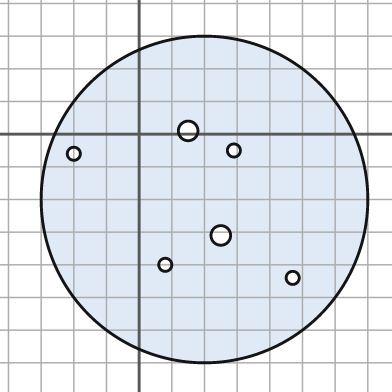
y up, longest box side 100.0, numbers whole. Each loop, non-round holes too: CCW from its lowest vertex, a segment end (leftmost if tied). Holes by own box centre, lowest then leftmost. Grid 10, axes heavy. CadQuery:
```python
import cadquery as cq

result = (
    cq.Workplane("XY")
    .moveTo(20.0, -20.0)
    .circle(50.0)
    .moveTo(47.0, -44.0)
    .circle(2.0)
    .moveTo(8.0, -40.0)
    .circle(2.0)
    .moveTo(25.0, -31.0)
    .circle(3.0)
    .moveTo(-20.0, -6.0)
    .circle(2.0)
    .moveTo(29.0, -5.0)
    .circle(2.0)
    .moveTo(15.0, 1.0)
    .circle(3.0)
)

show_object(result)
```